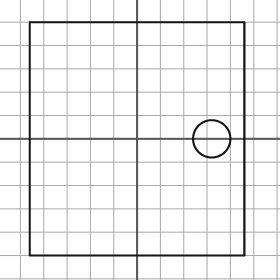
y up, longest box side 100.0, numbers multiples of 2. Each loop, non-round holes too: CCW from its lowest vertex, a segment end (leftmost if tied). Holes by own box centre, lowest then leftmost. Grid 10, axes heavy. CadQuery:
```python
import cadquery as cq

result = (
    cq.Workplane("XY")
    .moveTo(-46.0, -50.0)
    .lineTo(46.0, -50.0)
    .lineTo(46.0, 50.0)
    .lineTo(-46.0, 50.0)
    .close()
    .moveTo(32.0, 0.0)
    .circle(8.0)
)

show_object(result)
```